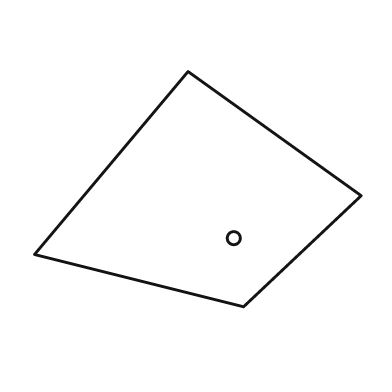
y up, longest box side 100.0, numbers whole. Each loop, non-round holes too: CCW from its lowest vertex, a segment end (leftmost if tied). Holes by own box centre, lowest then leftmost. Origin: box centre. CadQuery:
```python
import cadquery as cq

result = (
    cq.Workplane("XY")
    .moveTo(14.0, -36.0)
    .lineTo(50.0, -2.0)
    .lineTo(-3.0, 36.0)
    .lineTo(-50.0, -20.0)
    .close()
    .moveTo(11.0, -15.0)
    .circle(2.0)
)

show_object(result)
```